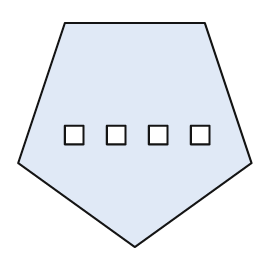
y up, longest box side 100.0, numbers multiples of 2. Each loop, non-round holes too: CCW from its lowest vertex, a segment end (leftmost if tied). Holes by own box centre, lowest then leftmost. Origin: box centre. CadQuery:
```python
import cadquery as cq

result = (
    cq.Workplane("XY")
    .moveTo(0.0, -48.0)
    .lineTo(50.0, -12.0)
    .lineTo(30.0, 48.0)
    .lineTo(-30.0, 48.0)
    .lineTo(-50.0, -12.0)
    .close()
    .moveTo(-30.0, -4.0)
    .lineTo(-22.0, -4.0)
    .lineTo(-22.0, 4.0)
    .lineTo(-30.0, 4.0)
    .close()
    .moveTo(-12.0, -4.0)
    .lineTo(-4.0, -4.0)
    .lineTo(-4.0, 4.0)
    .lineTo(-12.0, 4.0)
    .close()
    .moveTo(6.0, -4.0)
    .lineTo(14.0, -4.0)
    .lineTo(14.0, 4.0)
    .lineTo(6.0, 4.0)
    .close()
    .moveTo(24.0, -4.0)
    .lineTo(32.0, -4.0)
    .lineTo(32.0, 4.0)
    .lineTo(24.0, 4.0)
    .close()
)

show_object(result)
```